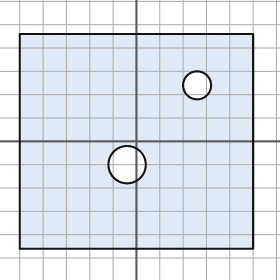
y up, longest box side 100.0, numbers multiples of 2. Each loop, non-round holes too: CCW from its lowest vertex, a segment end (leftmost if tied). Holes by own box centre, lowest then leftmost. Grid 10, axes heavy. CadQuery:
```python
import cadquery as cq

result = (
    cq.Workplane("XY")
    .moveTo(-50.0, -46.0)
    .lineTo(50.0, -46.0)
    .lineTo(50.0, 46.0)
    .lineTo(-50.0, 46.0)
    .close()
    .moveTo(-4.0, -10.0)
    .circle(8.0)
    .moveTo(26.0, 24.0)
    .circle(6.0)
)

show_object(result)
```